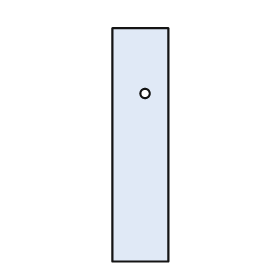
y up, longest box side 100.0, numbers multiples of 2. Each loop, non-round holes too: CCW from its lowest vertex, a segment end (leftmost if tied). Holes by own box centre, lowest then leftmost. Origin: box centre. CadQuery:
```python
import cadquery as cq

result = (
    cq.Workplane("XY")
    .moveTo(-12.0, -50.0)
    .lineTo(12.0, -50.0)
    .lineTo(12.0, 50.0)
    .lineTo(-12.0, 50.0)
    .close()
    .moveTo(2.0, 22.0)
    .circle(2.0)
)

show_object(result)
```